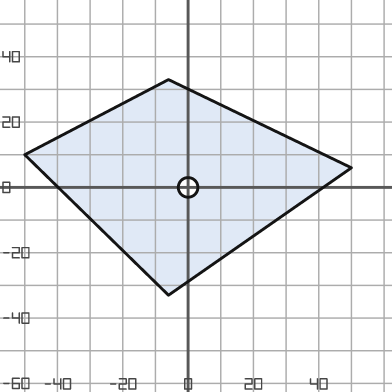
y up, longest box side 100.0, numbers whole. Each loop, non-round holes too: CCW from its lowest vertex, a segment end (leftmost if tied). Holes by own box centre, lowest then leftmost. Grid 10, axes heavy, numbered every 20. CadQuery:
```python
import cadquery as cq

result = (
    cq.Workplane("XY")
    .moveTo(-6.0, -33.0)
    .lineTo(50.0, 6.0)
    .lineTo(-6.0, 33.0)
    .lineTo(-50.0, 10.0)
    .close()
    .moveTo(0.0, 0.0)
    .circle(3.0)
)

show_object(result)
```